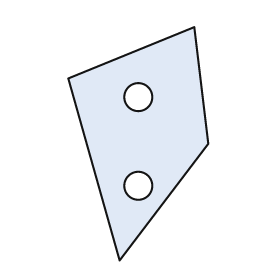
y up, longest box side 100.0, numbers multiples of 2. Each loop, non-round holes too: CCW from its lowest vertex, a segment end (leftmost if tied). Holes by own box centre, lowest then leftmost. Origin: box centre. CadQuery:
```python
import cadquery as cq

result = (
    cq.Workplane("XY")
    .moveTo(-8.0, -50.0)
    .lineTo(30.0, 0.0)
    .lineTo(24.0, 50.0)
    .lineTo(-30.0, 28.0)
    .close()
    .moveTo(0.0, -18.0)
    .circle(6.0)
    .moveTo(0.0, 20.0)
    .circle(6.0)
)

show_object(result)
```